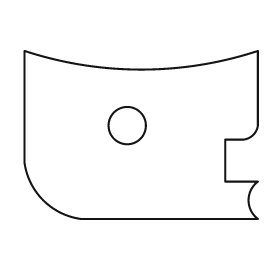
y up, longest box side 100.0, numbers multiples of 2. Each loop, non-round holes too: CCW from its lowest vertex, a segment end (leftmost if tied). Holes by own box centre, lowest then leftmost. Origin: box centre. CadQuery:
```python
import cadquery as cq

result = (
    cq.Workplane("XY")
    .moveTo(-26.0, -36.0)
    .lineTo(50.0, -36.0)
    .threePointArc((46.0, -28.0), (50.0, -20.0))
    .lineTo(36.0, -20.0)
    .lineTo(36.0, -2.0)
    .lineTo(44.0, -2.0)
    .threePointArc((48.0, 0.0), (50.0, 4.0))
    .lineTo(50.0, 36.0)
    .threePointArc((0.0, 28.0), (-50.0, 36.0))
    .lineTo(-50.0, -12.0)
    .threePointArc((-42.0, -28.0), (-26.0, -36.0))
    .close()
    .moveTo(-6.0, 4.0)
    .circle(8.0)
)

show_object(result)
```